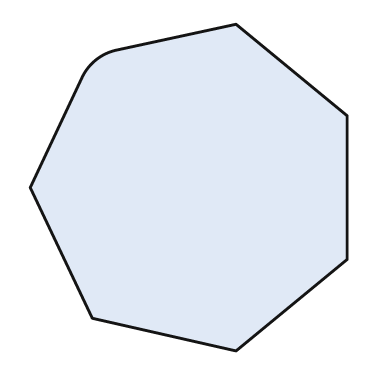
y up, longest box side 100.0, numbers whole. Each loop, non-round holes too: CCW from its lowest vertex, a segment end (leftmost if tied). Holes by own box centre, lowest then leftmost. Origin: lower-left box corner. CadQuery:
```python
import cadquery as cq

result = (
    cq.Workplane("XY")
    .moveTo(63.0, 0.0)
    .lineTo(97.0, 28.0)
    .lineTo(97.0, 72.0)
    .lineTo(63.0, 100.0)
    .lineTo(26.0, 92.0)
    .threePointArc((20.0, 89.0), (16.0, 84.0))
    .lineTo(0.0, 50.0)
    .lineTo(19.0, 10.0)
    .close()
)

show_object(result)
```